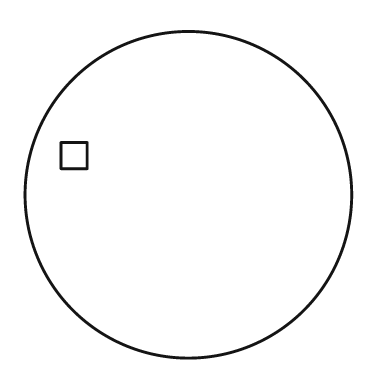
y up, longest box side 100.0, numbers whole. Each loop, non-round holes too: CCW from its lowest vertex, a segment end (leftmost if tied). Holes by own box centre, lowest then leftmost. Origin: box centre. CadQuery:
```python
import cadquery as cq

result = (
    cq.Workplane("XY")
    .moveTo(0.0, 0.0)
    .circle(50.0)
    .moveTo(-39.0, 8.0)
    .lineTo(-31.0, 8.0)
    .lineTo(-31.0, 16.0)
    .lineTo(-39.0, 16.0)
    .close()
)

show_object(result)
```